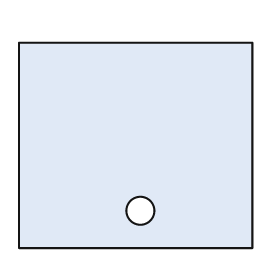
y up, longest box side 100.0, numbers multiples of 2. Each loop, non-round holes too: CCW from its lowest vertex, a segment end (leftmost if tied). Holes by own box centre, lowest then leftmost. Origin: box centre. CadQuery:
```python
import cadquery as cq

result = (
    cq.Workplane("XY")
    .moveTo(-50.0, -44.0)
    .lineTo(50.0, -44.0)
    .lineTo(50.0, 44.0)
    .lineTo(-50.0, 44.0)
    .close()
    .moveTo(2.0, -28.0)
    .circle(6.0)
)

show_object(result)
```